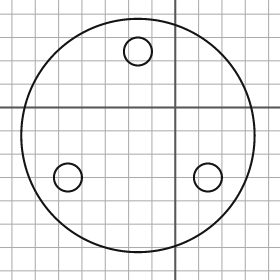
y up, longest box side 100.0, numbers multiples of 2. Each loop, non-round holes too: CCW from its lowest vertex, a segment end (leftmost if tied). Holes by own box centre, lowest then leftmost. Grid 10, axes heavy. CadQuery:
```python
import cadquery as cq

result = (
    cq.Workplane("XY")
    .moveTo(-16.0, -12.0)
    .circle(50.0)
    .moveTo(-46.0, -30.0)
    .circle(6.0)
    .moveTo(14.0, -30.0)
    .circle(6.0)
    .moveTo(-16.0, 24.0)
    .circle(6.0)
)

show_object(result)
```